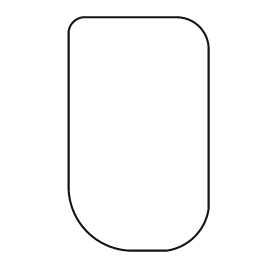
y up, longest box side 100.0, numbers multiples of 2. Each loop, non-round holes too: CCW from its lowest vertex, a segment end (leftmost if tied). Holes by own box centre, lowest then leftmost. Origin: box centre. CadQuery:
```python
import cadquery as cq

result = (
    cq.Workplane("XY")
    .moveTo(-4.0, -50.0)
    .lineTo(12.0, -50.0)
    .threePointArc((24.0, -44.0), (30.0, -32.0))
    .lineTo(30.0, 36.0)
    .threePointArc((26.0, 46.0), (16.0, 50.0))
    .lineTo(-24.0, 50.0)
    .threePointArc((-28.0, 48.0), (-30.0, 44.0))
    .lineTo(-30.0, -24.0)
    .threePointArc((-22.0, -42.0), (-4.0, -50.0))
    .close()
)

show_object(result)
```